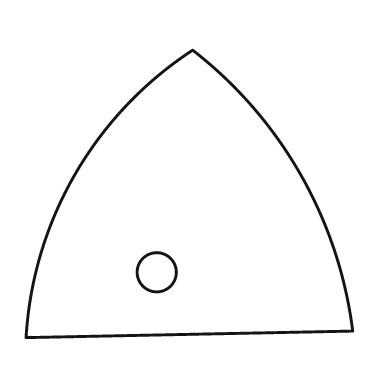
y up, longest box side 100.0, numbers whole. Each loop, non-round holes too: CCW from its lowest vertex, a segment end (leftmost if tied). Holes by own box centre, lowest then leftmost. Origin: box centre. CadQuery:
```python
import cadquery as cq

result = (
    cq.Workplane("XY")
    .moveTo(-50.0, -44.0)
    .lineTo(50.0, -42.0)
    .threePointArc((34.0, 6.0), (1.0, 44.0))
    .threePointArc((-35.0, 6.0), (-50.0, -44.0))
    .close()
    .moveTo(-10.0, -24.0)
    .circle(6.0)
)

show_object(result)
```